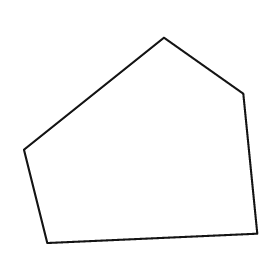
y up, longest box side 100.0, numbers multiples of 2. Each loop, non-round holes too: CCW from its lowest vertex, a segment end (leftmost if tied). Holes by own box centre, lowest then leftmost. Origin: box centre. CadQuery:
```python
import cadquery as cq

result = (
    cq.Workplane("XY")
    .moveTo(-40.0, -44.0)
    .lineTo(50.0, -40.0)
    .lineTo(44.0, 20.0)
    .lineTo(10.0, 44.0)
    .lineTo(-50.0, -4.0)
    .close()
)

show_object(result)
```